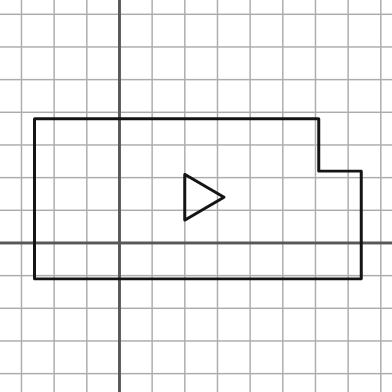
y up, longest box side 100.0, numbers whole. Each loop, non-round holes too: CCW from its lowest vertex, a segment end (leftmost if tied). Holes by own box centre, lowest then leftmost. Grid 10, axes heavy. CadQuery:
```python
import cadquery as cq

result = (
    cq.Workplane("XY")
    .moveTo(-26.0, -11.0)
    .lineTo(74.0, -11.0)
    .lineTo(74.0, 22.0)
    .lineTo(61.0, 22.0)
    .lineTo(61.0, 38.0)
    .lineTo(-26.0, 38.0)
    .close()
    .moveTo(20.0, 7.0)
    .lineTo(32.0, 14.0)
    .lineTo(20.0, 21.0)
    .close()
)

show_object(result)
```